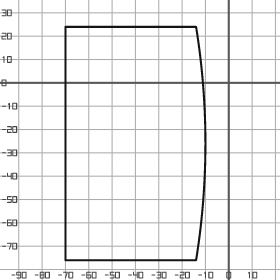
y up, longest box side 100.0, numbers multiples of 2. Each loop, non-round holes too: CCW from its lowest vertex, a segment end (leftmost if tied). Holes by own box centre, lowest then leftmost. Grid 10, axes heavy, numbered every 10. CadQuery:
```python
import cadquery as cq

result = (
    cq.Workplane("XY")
    .moveTo(-70.0, -76.0)
    .lineTo(-14.0, -76.0)
    .threePointArc((-10.0, -26.0), (-14.0, 24.0))
    .lineTo(-70.0, 24.0)
    .close()
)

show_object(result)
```